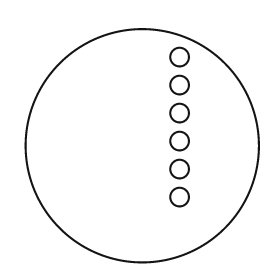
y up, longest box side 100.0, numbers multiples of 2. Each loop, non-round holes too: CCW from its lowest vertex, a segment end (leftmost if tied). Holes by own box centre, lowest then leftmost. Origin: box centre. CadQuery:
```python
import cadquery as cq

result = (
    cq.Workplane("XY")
    .moveTo(0.0, 0.0)
    .circle(50.0)
    .moveTo(16.0, -22.0)
    .circle(4.0)
    .moveTo(16.0, -10.0)
    .circle(4.0)
    .moveTo(16.0, 2.0)
    .circle(4.0)
    .moveTo(16.0, 14.0)
    .circle(4.0)
    .moveTo(16.0, 26.0)
    .circle(4.0)
    .moveTo(16.0, 38.0)
    .circle(4.0)
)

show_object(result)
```